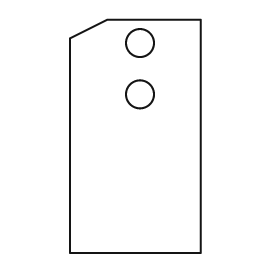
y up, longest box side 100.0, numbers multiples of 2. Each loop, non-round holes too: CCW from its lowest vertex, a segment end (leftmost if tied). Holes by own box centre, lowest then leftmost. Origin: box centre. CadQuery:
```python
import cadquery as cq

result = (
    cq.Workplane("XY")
    .moveTo(-28.0, -50.0)
    .lineTo(28.0, -50.0)
    .lineTo(28.0, 50.0)
    .lineTo(-12.0, 50.0)
    .lineTo(-28.0, 42.0)
    .close()
    .moveTo(2.0, 18.0)
    .circle(6.0)
    .moveTo(2.0, 40.0)
    .circle(6.0)
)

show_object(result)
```